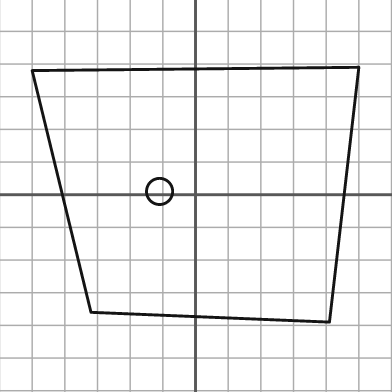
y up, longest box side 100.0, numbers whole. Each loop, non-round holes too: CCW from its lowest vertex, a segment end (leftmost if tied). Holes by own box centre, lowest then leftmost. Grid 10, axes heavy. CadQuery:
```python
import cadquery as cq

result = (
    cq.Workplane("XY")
    .moveTo(41.0, -39.0)
    .lineTo(50.0, 39.0)
    .lineTo(-50.0, 38.0)
    .lineTo(-32.0, -36.0)
    .close()
    .moveTo(-11.0, 1.0)
    .circle(4.0)
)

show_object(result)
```